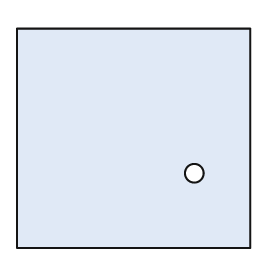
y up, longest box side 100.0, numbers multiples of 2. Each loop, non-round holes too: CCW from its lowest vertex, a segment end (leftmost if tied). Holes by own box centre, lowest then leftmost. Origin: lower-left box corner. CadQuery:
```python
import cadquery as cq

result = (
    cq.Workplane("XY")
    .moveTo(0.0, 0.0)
    .lineTo(100.0, 0.0)
    .lineTo(100.0, 94.0)
    .lineTo(0.0, 94.0)
    .close()
    .moveTo(76.0, 32.0)
    .circle(4.0)
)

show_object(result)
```